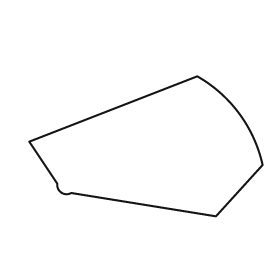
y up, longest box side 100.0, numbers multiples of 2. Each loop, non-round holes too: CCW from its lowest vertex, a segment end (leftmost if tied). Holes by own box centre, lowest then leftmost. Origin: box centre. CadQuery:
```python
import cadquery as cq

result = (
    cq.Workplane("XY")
    .moveTo(30.0, -30.0)
    .lineTo(50.0, -8.0)
    .threePointArc((40.0, 14.0), (22.0, 30.0))
    .lineTo(-50.0, 2.0)
    .lineTo(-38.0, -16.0)
    .threePointArc((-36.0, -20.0), (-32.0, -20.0))
    .close()
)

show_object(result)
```